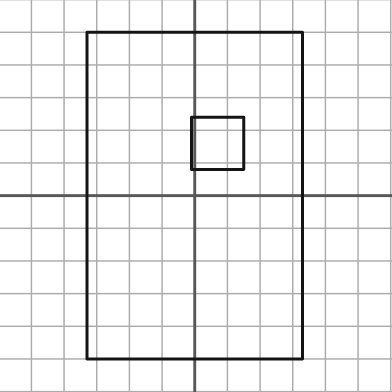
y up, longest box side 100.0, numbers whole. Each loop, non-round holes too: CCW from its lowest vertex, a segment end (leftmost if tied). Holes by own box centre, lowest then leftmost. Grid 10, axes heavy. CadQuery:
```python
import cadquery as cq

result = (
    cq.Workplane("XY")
    .moveTo(-33.0, -50.0)
    .lineTo(33.0, -50.0)
    .lineTo(33.0, 50.0)
    .lineTo(-33.0, 50.0)
    .close()
    .moveTo(-1.0, 8.0)
    .lineTo(15.0, 8.0)
    .lineTo(15.0, 24.0)
    .lineTo(-1.0, 24.0)
    .close()
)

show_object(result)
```